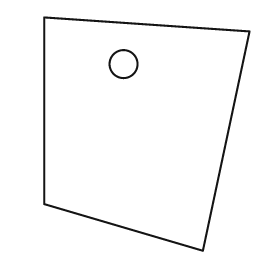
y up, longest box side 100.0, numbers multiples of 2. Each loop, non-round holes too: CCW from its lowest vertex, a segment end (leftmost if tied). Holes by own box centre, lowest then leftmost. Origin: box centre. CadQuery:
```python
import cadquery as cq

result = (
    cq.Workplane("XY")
    .moveTo(24.0, -50.0)
    .lineTo(44.0, 44.0)
    .lineTo(-44.0, 50.0)
    .lineTo(-44.0, -30.0)
    .close()
    .moveTo(-10.0, 30.0)
    .circle(6.0)
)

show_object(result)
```